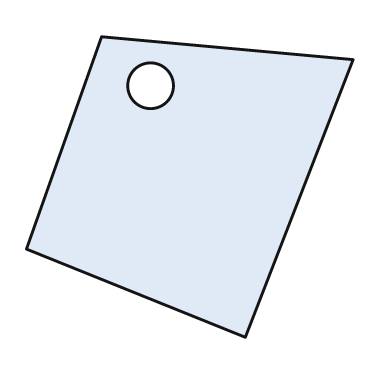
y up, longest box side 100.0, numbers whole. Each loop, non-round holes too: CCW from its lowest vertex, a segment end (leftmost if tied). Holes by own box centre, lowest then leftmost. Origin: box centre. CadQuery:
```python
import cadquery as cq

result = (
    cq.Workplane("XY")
    .moveTo(17.0, -46.0)
    .lineTo(50.0, 39.0)
    .lineTo(-27.0, 46.0)
    .lineTo(-50.0, -19.0)
    .close()
    .moveTo(-12.0, 31.0)
    .circle(7.0)
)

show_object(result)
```